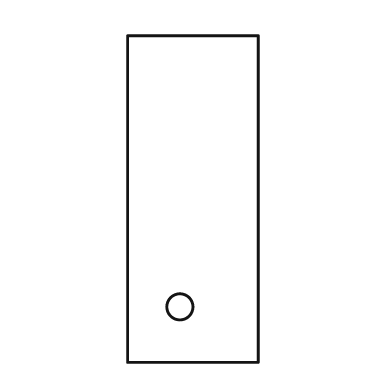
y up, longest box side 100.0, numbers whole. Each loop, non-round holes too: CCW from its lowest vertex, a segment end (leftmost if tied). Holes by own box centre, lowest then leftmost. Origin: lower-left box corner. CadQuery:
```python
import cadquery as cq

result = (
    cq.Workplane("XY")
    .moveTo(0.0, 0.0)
    .lineTo(40.0, 0.0)
    .lineTo(40.0, 100.0)
    .lineTo(0.0, 100.0)
    .close()
    .moveTo(16.0, 17.0)
    .circle(4.0)
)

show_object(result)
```